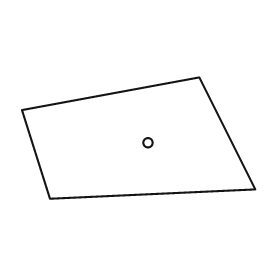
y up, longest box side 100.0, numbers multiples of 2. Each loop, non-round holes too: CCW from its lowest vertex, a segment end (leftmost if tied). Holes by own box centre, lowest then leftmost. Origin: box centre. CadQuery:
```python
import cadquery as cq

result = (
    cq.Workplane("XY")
    .moveTo(-38.0, -26.0)
    .lineTo(50.0, -22.0)
    .lineTo(26.0, 26.0)
    .lineTo(-50.0, 12.0)
    .close()
    .moveTo(4.0, -2.0)
    .circle(2.0)
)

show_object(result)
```